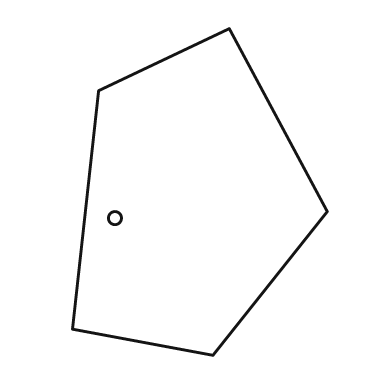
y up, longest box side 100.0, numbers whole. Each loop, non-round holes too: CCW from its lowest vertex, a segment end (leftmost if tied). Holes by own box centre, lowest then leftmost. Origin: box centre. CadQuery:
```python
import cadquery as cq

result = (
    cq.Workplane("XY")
    .moveTo(4.0, -50.0)
    .lineTo(39.0, -6.0)
    .lineTo(9.0, 50.0)
    .lineTo(-31.0, 31.0)
    .lineTo(-39.0, -42.0)
    .close()
    .moveTo(-26.0, -8.0)
    .circle(2.0)
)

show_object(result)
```